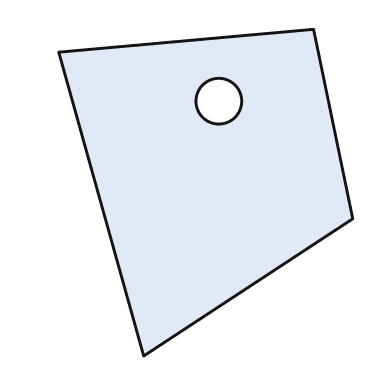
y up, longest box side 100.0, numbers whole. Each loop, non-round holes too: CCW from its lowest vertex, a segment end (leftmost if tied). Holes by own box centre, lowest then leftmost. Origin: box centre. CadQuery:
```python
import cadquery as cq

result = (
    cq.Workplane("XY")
    .moveTo(-19.0, -50.0)
    .lineTo(45.0, -8.0)
    .lineTo(33.0, 50.0)
    .lineTo(-45.0, 43.0)
    .close()
    .moveTo(4.0, 28.0)
    .circle(7.0)
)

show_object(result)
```